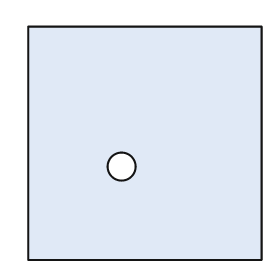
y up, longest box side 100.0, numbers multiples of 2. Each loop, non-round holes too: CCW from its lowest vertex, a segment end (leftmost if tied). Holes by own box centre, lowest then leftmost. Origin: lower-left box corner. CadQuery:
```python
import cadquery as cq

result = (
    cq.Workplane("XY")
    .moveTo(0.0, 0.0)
    .lineTo(100.0, 0.0)
    .lineTo(100.0, 100.0)
    .lineTo(0.0, 100.0)
    .close()
    .moveTo(40.0, 40.0)
    .circle(6.0)
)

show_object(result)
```